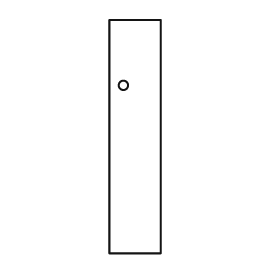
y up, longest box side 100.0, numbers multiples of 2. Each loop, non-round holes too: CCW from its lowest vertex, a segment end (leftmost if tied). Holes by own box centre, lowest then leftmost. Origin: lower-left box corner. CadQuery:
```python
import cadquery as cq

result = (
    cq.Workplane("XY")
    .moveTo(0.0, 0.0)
    .lineTo(22.0, 0.0)
    .lineTo(22.0, 100.0)
    .lineTo(0.0, 100.0)
    .close()
    .moveTo(6.0, 72.0)
    .circle(2.0)
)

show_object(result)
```